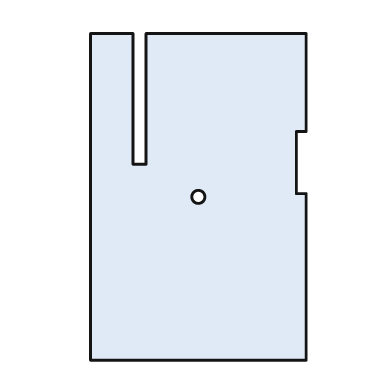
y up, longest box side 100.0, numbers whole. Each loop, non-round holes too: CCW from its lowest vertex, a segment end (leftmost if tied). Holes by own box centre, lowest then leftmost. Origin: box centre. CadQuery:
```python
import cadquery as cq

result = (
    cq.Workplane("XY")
    .moveTo(-33.0, -50.0)
    .lineTo(33.0, -50.0)
    .lineTo(33.0, 1.0)
    .lineTo(30.0, 1.0)
    .lineTo(30.0, 20.0)
    .lineTo(33.0, 20.0)
    .lineTo(33.0, 50.0)
    .lineTo(-16.0, 50.0)
    .lineTo(-16.0, 10.0)
    .lineTo(-20.0, 10.0)
    .lineTo(-20.0, 50.0)
    .lineTo(-33.0, 50.0)
    .close()
    .moveTo(0.0, 0.0)
    .circle(2.0)
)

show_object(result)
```